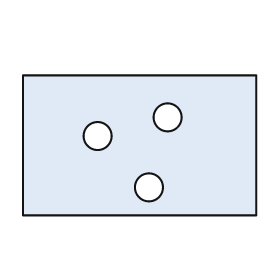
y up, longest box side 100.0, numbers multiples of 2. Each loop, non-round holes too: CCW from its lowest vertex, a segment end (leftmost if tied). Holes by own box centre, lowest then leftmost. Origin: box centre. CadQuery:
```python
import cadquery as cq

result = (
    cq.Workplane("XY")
    .moveTo(-50.0, -30.0)
    .lineTo(50.0, -30.0)
    .lineTo(50.0, 30.0)
    .lineTo(-50.0, 30.0)
    .close()
    .moveTo(4.0, -18.0)
    .circle(6.0)
    .moveTo(-18.0, 4.0)
    .circle(6.0)
    .moveTo(12.0, 12.0)
    .circle(6.0)
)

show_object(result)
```